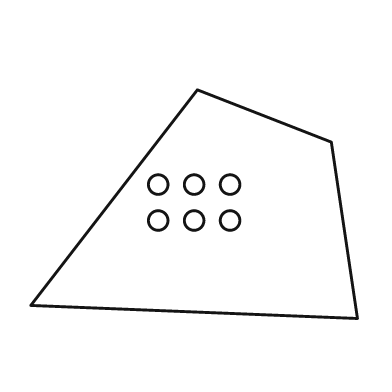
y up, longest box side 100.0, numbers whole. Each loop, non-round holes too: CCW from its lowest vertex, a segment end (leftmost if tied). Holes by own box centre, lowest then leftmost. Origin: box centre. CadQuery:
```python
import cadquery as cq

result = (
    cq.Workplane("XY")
    .moveTo(50.0, -35.0)
    .lineTo(42.0, 19.0)
    .lineTo(1.0, 35.0)
    .lineTo(-50.0, -31.0)
    .close()
    .moveTo(-11.0, -5.0)
    .circle(3.0)
    .moveTo(0.0, -5.0)
    .circle(3.0)
    .moveTo(11.0, -5.0)
    .circle(3.0)
    .moveTo(-11.0, 6.0)
    .circle(3.0)
    .moveTo(0.0, 6.0)
    .circle(3.0)
    .moveTo(11.0, 6.0)
    .circle(3.0)
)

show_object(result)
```